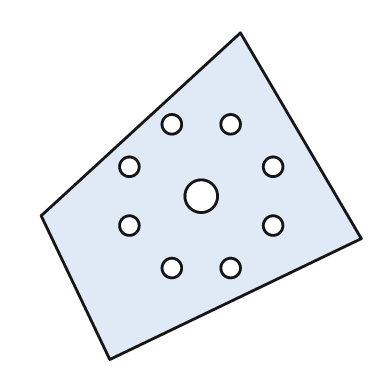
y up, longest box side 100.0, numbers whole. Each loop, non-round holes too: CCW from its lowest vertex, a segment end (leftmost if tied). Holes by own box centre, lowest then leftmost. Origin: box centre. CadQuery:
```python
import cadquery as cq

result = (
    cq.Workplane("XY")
    .moveTo(-28.0, -50.0)
    .lineTo(49.0, -13.0)
    .lineTo(12.0, 50.0)
    .lineTo(-49.0, -6.0)
    .close()
    .moveTo(-9.0, -22.0)
    .circle(3.0)
    .moveTo(9.0, -22.0)
    .circle(3.0)
    .moveTo(-22.0, -9.0)
    .circle(3.0)
    .moveTo(22.0, -9.0)
    .circle(3.0)
    .moveTo(0.0, 0.0)
    .circle(5.0)
    .moveTo(-22.0, 9.0)
    .circle(3.0)
    .moveTo(22.0, 9.0)
    .circle(3.0)
    .moveTo(-9.0, 22.0)
    .circle(3.0)
    .moveTo(9.0, 22.0)
    .circle(3.0)
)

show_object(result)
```